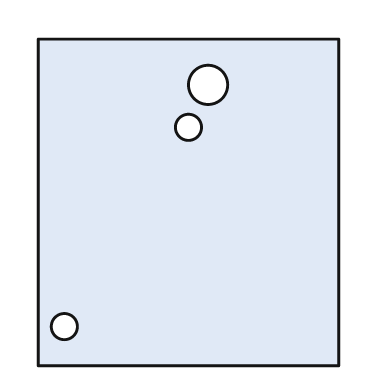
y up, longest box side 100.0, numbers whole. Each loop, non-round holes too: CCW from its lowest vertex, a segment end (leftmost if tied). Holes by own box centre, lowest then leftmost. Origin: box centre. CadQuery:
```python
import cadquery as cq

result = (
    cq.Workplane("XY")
    .moveTo(-46.0, -50.0)
    .lineTo(46.0, -50.0)
    .lineTo(46.0, 50.0)
    .lineTo(-46.0, 50.0)
    .close()
    .moveTo(-38.0, -38.0)
    .circle(4.0)
    .moveTo(0.0, 23.0)
    .circle(4.0)
    .moveTo(6.0, 36.0)
    .circle(6.0)
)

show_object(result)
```